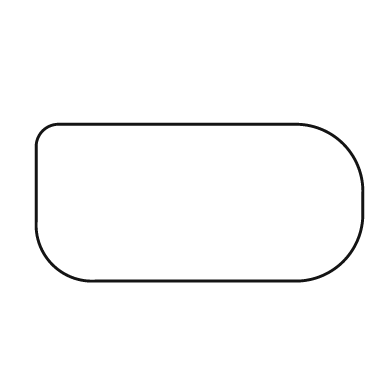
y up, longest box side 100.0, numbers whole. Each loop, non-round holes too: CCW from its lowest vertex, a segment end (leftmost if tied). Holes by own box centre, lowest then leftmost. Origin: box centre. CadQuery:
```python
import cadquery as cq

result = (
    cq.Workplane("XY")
    .moveTo(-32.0, -24.0)
    .lineTo(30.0, -24.0)
    .threePointArc((44.0, -18.0), (50.0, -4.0))
    .lineTo(50.0, 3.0)
    .threePointArc((44.0, 18.0), (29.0, 24.0))
    .lineTo(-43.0, 24.0)
    .threePointArc((-48.0, 22.0), (-50.0, 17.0))
    .lineTo(-50.0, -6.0)
    .threePointArc((-45.0, -19.0), (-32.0, -24.0))
    .close()
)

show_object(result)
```